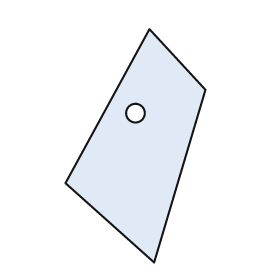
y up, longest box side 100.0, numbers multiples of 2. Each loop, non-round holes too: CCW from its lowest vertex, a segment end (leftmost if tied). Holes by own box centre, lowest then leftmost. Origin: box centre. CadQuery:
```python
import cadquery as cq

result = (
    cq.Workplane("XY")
    .moveTo(8.0, -50.0)
    .lineTo(30.0, 24.0)
    .lineTo(6.0, 50.0)
    .lineTo(-30.0, -16.0)
    .close()
    .moveTo(0.0, 14.0)
    .circle(4.0)
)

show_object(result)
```